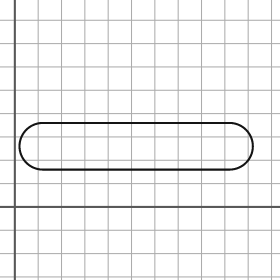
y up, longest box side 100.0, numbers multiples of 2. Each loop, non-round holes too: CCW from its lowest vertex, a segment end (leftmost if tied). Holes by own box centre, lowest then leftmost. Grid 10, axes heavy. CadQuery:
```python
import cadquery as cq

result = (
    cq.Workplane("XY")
    .moveTo(12.0, 16.0)
    .lineTo(92.0, 16.0)
    .threePointArc((102.0, 26.0), (92.0, 36.0))
    .lineTo(12.0, 36.0)
    .threePointArc((2.0, 26.0), (12.0, 16.0))
    .close()
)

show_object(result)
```